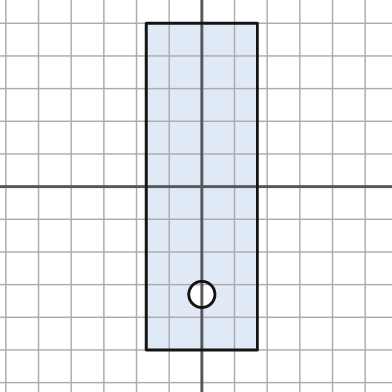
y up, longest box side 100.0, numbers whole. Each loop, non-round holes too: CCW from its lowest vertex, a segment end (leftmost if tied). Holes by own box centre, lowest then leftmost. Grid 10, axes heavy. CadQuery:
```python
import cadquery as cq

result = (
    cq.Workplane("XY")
    .moveTo(-17.0, -50.0)
    .lineTo(17.0, -50.0)
    .lineTo(17.0, 50.0)
    .lineTo(-17.0, 50.0)
    .close()
    .moveTo(0.0, -33.0)
    .circle(4.0)
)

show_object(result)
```